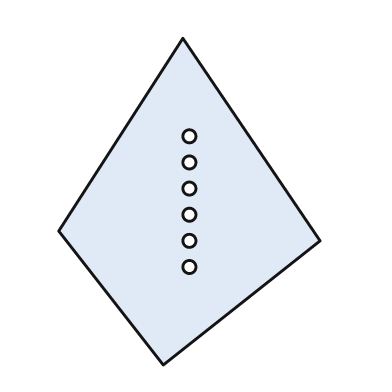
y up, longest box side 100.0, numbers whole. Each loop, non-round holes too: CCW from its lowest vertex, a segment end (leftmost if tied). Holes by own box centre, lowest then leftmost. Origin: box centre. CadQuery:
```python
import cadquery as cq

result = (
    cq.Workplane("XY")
    .moveTo(-8.0, -50.0)
    .lineTo(40.0, -12.0)
    .lineTo(-2.0, 50.0)
    .lineTo(-40.0, -9.0)
    .close()
    .moveTo(0.0, -20.0)
    .circle(2.0)
    .moveTo(0.0, -12.0)
    .circle(2.0)
    .moveTo(0.0, -4.0)
    .circle(2.0)
    .moveTo(0.0, 4.0)
    .circle(2.0)
    .moveTo(0.0, 12.0)
    .circle(2.0)
    .moveTo(0.0, 20.0)
    .circle(2.0)
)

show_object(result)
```